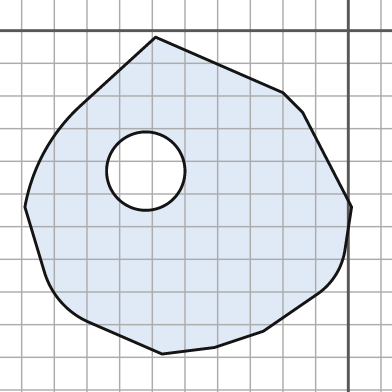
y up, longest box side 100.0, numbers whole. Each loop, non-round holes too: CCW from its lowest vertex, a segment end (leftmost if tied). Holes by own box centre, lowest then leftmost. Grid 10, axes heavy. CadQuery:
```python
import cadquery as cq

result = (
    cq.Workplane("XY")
    .moveTo(-57.0, -99.0)
    .lineTo(-41.0, -97.0)
    .lineTo(-26.0, -92.0)
    .lineTo(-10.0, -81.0)
    .threePointArc((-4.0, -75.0), (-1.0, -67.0))
    .lineTo(1.0, -54.0)
    .lineTo(-14.0, -25.0)
    .lineTo(-20.0, -19.0)
    .lineTo(-59.0, -2.0)
    .lineTo(-82.0, -23.0)
    .threePointArc((-93.0, -37.0), (-99.0, -54.0))
    .lineTo(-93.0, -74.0)
    .threePointArc((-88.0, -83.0), (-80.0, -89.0))
    .close()
    .moveTo(-62.0, -43.0)
    .circle(12.0)
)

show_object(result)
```